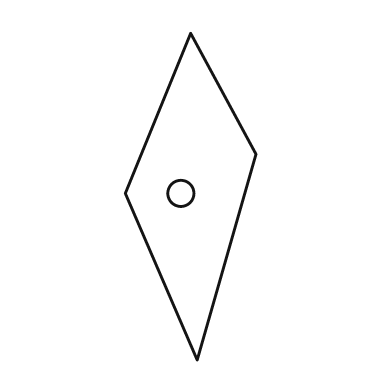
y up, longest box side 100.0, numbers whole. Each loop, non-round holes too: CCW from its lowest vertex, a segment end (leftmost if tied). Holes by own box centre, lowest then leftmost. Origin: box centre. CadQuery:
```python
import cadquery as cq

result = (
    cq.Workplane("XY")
    .moveTo(2.0, -50.0)
    .lineTo(20.0, 13.0)
    .lineTo(0.0, 50.0)
    .lineTo(-20.0, 1.0)
    .close()
    .moveTo(-3.0, 1.0)
    .circle(4.0)
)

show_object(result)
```